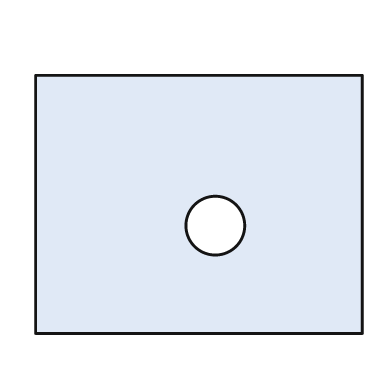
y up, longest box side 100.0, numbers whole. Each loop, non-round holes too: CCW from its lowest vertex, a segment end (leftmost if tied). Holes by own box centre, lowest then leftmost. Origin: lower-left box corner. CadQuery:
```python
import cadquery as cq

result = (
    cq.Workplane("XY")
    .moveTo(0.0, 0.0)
    .lineTo(100.0, 0.0)
    .lineTo(100.0, 79.0)
    .lineTo(0.0, 79.0)
    .close()
    .moveTo(55.0, 33.0)
    .circle(9.0)
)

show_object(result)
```